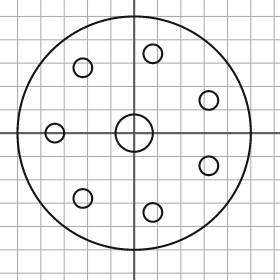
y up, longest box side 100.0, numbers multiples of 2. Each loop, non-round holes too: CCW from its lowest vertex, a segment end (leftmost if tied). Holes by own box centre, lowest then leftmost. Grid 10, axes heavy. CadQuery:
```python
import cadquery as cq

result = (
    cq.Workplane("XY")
    .moveTo(0.0, 0.0)
    .circle(50.0)
    .moveTo(8.0, -34.0)
    .circle(4.0)
    .moveTo(-22.0, -28.0)
    .circle(4.0)
    .moveTo(32.0, -14.0)
    .circle(4.0)
    .moveTo(-34.0, 0.0)
    .circle(4.0)
    .moveTo(0.0, 0.0)
    .circle(8.0)
    .moveTo(32.0, 14.0)
    .circle(4.0)
    .moveTo(-22.0, 28.0)
    .circle(4.0)
    .moveTo(8.0, 34.0)
    .circle(4.0)
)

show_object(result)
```